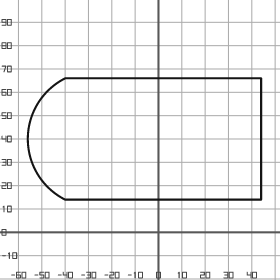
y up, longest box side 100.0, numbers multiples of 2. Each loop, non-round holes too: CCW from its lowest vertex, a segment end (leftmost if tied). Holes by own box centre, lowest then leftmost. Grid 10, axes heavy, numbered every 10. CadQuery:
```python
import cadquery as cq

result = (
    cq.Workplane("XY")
    .moveTo(-40.0, 14.0)
    .lineTo(44.0, 14.0)
    .lineTo(44.0, 66.0)
    .lineTo(-40.0, 66.0)
    .threePointArc((-56.0, 40.0), (-40.0, 14.0))
    .close()
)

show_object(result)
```